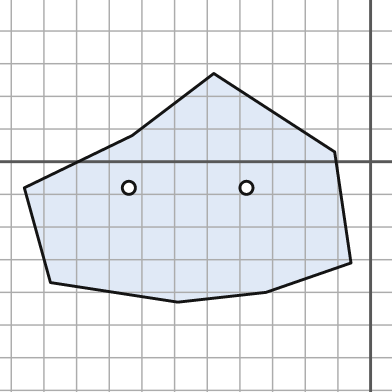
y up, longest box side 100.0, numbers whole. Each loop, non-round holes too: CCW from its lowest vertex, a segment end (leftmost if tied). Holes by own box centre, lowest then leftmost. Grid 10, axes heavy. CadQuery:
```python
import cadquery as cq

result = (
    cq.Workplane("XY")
    .moveTo(-59.0, -43.0)
    .lineTo(-32.0, -40.0)
    .lineTo(-6.0, -31.0)
    .lineTo(-11.0, 3.0)
    .lineTo(-48.0, 27.0)
    .lineTo(-73.0, 8.0)
    .lineTo(-106.0, -8.0)
    .lineTo(-98.0, -37.0)
    .close()
    .moveTo(-74.0, -8.0)
    .circle(2.0)
    .moveTo(-38.0, -8.0)
    .circle(2.0)
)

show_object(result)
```